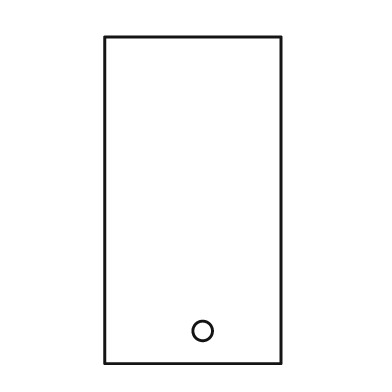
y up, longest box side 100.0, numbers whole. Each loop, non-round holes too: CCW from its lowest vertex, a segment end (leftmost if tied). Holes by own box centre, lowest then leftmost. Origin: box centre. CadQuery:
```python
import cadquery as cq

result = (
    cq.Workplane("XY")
    .moveTo(-27.0, -50.0)
    .lineTo(27.0, -50.0)
    .lineTo(27.0, 50.0)
    .lineTo(-27.0, 50.0)
    .close()
    .moveTo(3.0, -40.0)
    .circle(3.0)
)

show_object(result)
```